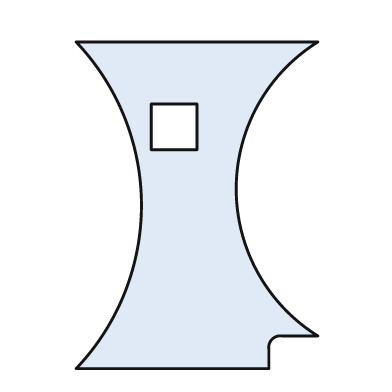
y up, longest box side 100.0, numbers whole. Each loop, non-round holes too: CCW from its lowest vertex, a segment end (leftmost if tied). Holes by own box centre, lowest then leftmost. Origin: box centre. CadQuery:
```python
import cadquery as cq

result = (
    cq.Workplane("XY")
    .moveTo(-37.0, -50.0)
    .lineTo(22.0, -50.0)
    .lineTo(22.0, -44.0)
    .threePointArc((23.0, -41.0), (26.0, -40.0))
    .lineTo(37.0, -40.0)
    .threePointArc((12.0, 5.0), (37.0, 50.0))
    .lineTo(-37.0, 50.0)
    .threePointArc((-17.0, 0.0), (-37.0, -50.0))
    .close()
    .moveTo(-14.0, 17.0)
    .lineTo(0.0, 17.0)
    .lineTo(0.0, 31.0)
    .lineTo(-14.0, 31.0)
    .close()
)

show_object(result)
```